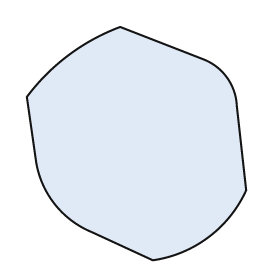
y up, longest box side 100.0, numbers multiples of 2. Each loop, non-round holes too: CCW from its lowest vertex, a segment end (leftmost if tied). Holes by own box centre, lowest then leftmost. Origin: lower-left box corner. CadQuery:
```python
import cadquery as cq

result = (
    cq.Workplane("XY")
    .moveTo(54.0, 0.0)
    .threePointArc((78.0, 10.0), (94.0, 30.0))
    .lineTo(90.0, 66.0)
    .threePointArc((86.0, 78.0), (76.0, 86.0))
    .lineTo(40.0, 100.0)
    .threePointArc((18.0, 88.0), (0.0, 70.0))
    .lineTo(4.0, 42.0)
    .threePointArc((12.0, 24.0), (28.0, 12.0))
    .close()
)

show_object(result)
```